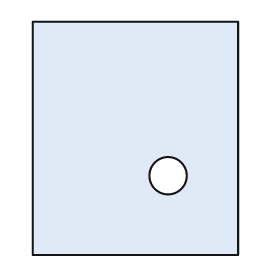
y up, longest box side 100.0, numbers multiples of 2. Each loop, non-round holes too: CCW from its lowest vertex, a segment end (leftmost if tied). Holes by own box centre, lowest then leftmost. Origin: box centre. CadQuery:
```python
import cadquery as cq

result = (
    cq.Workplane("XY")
    .moveTo(-44.0, -50.0)
    .lineTo(44.0, -50.0)
    .lineTo(44.0, 50.0)
    .lineTo(-44.0, 50.0)
    .close()
    .moveTo(14.0, -16.0)
    .circle(8.0)
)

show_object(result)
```